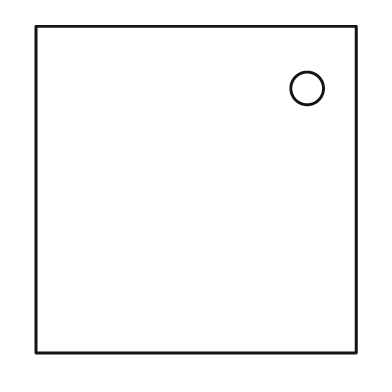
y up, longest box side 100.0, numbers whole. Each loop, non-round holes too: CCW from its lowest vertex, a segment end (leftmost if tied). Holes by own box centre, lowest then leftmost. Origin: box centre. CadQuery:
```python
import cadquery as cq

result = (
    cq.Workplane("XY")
    .moveTo(-49.0, -50.0)
    .lineTo(49.0, -50.0)
    .lineTo(49.0, 50.0)
    .lineTo(-49.0, 50.0)
    .close()
    .moveTo(34.0, 31.0)
    .circle(5.0)
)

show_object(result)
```